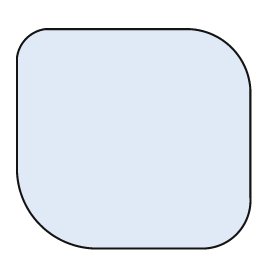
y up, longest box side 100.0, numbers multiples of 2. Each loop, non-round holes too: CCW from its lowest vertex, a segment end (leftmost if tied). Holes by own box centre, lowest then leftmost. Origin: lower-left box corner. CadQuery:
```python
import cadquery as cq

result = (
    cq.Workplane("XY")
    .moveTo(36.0, 0.0)
    .lineTo(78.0, 0.0)
    .threePointArc((94.0, 6.0), (100.0, 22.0))
    .lineTo(100.0, 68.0)
    .threePointArc((92.0, 86.0), (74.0, 94.0))
    .lineTo(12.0, 94.0)
    .threePointArc((4.0, 90.0), (0.0, 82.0))
    .lineTo(0.0, 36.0)
    .threePointArc((10.0, 10.0), (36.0, 0.0))
    .close()
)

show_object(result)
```